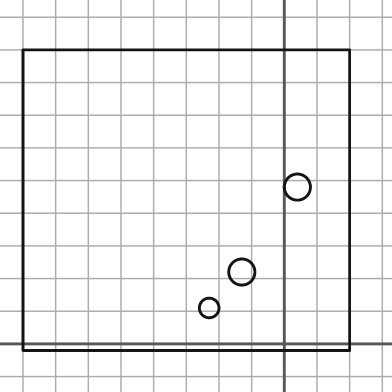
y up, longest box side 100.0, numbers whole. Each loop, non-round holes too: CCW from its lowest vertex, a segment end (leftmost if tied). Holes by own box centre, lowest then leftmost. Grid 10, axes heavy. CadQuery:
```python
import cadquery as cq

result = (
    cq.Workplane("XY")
    .moveTo(-80.0, -2.0)
    .lineTo(20.0, -2.0)
    .lineTo(20.0, 90.0)
    .lineTo(-80.0, 90.0)
    .close()
    .moveTo(-23.0, 11.0)
    .circle(3.0)
    .moveTo(-13.0, 22.0)
    .circle(4.0)
    .moveTo(4.0, 48.0)
    .circle(4.0)
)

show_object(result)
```